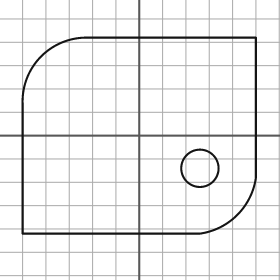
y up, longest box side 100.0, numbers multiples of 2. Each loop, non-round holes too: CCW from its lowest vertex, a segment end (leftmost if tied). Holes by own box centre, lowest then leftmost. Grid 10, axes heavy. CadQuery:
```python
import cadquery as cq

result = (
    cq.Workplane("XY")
    .moveTo(-50.0, -42.0)
    .lineTo(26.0, -42.0)
    .threePointArc((42.0, -34.0), (50.0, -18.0))
    .lineTo(50.0, 42.0)
    .lineTo(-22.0, 42.0)
    .threePointArc((-42.0, 34.0), (-50.0, 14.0))
    .close()
    .moveTo(26.0, -14.0)
    .circle(8.0)
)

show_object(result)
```